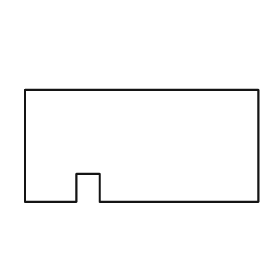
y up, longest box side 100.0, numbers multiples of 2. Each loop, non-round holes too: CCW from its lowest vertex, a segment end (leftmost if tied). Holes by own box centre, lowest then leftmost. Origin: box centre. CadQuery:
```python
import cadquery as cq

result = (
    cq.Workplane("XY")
    .moveTo(-50.0, -24.0)
    .lineTo(-28.0, -24.0)
    .lineTo(-28.0, -12.0)
    .lineTo(-18.0, -12.0)
    .lineTo(-18.0, -24.0)
    .lineTo(50.0, -24.0)
    .lineTo(50.0, 24.0)
    .lineTo(-50.0, 24.0)
    .close()
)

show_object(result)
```